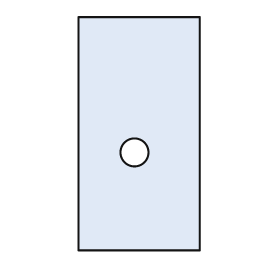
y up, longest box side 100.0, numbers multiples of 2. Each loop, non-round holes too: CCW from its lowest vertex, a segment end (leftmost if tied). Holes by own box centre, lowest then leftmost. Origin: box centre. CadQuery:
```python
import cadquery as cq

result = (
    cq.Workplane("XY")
    .moveTo(-26.0, -50.0)
    .lineTo(26.0, -50.0)
    .lineTo(26.0, 50.0)
    .lineTo(-26.0, 50.0)
    .close()
    .moveTo(-2.0, -8.0)
    .circle(6.0)
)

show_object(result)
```